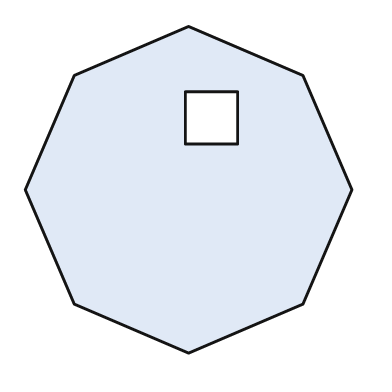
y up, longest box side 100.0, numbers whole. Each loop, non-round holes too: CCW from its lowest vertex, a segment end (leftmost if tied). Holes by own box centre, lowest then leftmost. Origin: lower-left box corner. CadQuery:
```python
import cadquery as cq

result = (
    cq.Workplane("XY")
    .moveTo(50.0, 0.0)
    .lineTo(85.0, 15.0)
    .lineTo(100.0, 50.0)
    .lineTo(85.0, 85.0)
    .lineTo(50.0, 100.0)
    .lineTo(15.0, 85.0)
    .lineTo(0.0, 50.0)
    .lineTo(15.0, 15.0)
    .close()
    .moveTo(49.0, 64.0)
    .lineTo(65.0, 64.0)
    .lineTo(65.0, 80.0)
    .lineTo(49.0, 80.0)
    .close()
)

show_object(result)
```